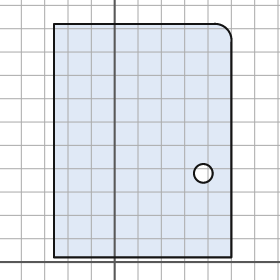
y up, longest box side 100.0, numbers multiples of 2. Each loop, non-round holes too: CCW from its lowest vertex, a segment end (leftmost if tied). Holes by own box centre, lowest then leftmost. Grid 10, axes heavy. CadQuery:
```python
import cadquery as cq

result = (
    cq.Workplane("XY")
    .moveTo(-26.0, 2.0)
    .lineTo(50.0, 2.0)
    .lineTo(50.0, 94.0)
    .threePointArc((48.0, 100.0), (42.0, 102.0))
    .lineTo(-26.0, 102.0)
    .close()
    .moveTo(38.0, 38.0)
    .circle(4.0)
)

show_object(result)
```